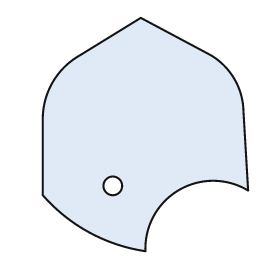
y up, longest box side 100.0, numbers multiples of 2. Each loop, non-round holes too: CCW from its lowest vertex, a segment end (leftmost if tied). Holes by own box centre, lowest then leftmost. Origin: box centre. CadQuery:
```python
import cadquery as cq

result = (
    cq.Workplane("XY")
    .moveTo(0.0, -50.0)
    .threePointArc((14.0, -24.0), (44.0, -24.0))
    .lineTo(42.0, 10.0)
    .threePointArc((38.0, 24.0), (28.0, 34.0))
    .lineTo(-2.0, 50.0)
    .lineTo(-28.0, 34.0)
    .threePointArc((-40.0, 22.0), (-44.0, 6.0))
    .lineTo(-44.0, -26.0)
    .threePointArc((-24.0, -42.0), (0.0, -50.0))
    .close()
    .moveTo(-14.0, -22.0)
    .circle(4.0)
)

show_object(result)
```